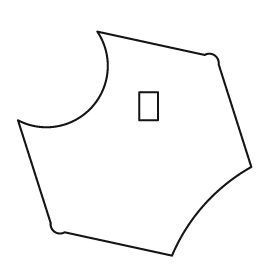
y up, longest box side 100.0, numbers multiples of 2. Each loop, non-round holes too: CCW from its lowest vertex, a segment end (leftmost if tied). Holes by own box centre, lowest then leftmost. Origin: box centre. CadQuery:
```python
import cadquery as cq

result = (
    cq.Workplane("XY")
    .moveTo(16.0, -48.0)
    .threePointArc((30.0, -26.0), (50.0, -10.0))
    .lineTo(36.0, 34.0)
    .threePointArc((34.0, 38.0), (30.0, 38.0))
    .lineTo(-16.0, 48.0)
    .threePointArc((-18.0, 16.0), (-50.0, 10.0))
    .lineTo(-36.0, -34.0)
    .threePointArc((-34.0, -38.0), (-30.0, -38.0))
    .close()
    .moveTo(2.0, 10.0)
    .lineTo(10.0, 10.0)
    .lineTo(10.0, 22.0)
    .lineTo(2.0, 22.0)
    .close()
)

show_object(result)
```